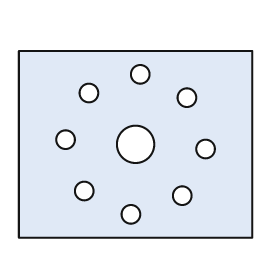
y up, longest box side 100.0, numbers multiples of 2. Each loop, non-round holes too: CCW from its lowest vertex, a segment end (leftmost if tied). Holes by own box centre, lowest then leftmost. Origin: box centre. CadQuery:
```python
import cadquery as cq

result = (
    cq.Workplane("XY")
    .moveTo(-50.0, -40.0)
    .lineTo(50.0, -40.0)
    .lineTo(50.0, 40.0)
    .lineTo(-50.0, 40.0)
    .close()
    .moveTo(-2.0, -30.0)
    .circle(4.0)
    .moveTo(20.0, -22.0)
    .circle(4.0)
    .moveTo(-22.0, -20.0)
    .circle(4.0)
    .moveTo(30.0, -2.0)
    .circle(4.0)
    .moveTo(0.0, 0.0)
    .circle(8.0)
    .moveTo(-30.0, 2.0)
    .circle(4.0)
    .moveTo(22.0, 20.0)
    .circle(4.0)
    .moveTo(-20.0, 22.0)
    .circle(4.0)
    .moveTo(2.0, 30.0)
    .circle(4.0)
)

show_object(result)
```